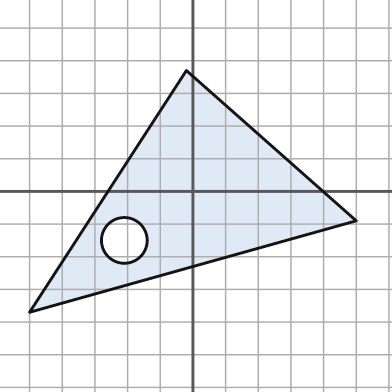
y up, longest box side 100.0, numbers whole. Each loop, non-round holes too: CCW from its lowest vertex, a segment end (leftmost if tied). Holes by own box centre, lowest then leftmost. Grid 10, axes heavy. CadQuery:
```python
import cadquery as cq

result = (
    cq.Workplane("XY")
    .moveTo(-50.0, -37.0)
    .lineTo(50.0, -9.0)
    .lineTo(-2.0, 37.0)
    .close()
    .moveTo(-21.0, -15.0)
    .circle(7.0)
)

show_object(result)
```